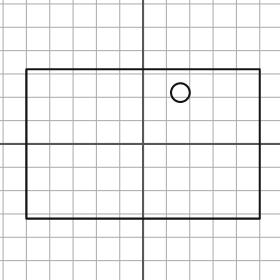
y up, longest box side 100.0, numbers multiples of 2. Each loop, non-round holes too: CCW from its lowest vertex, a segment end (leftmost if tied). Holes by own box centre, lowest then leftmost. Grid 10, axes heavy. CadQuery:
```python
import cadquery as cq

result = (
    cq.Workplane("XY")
    .moveTo(-50.0, -32.0)
    .lineTo(50.0, -32.0)
    .lineTo(50.0, 32.0)
    .lineTo(-50.0, 32.0)
    .close()
    .moveTo(16.0, 22.0)
    .circle(4.0)
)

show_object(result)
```